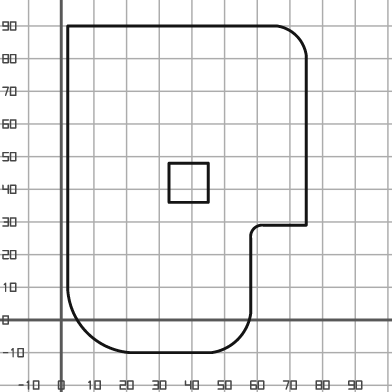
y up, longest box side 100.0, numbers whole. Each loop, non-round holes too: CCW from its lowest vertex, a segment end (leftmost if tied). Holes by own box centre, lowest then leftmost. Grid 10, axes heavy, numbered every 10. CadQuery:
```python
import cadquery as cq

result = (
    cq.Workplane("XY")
    .moveTo(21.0, -10.0)
    .lineTo(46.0, -10.0)
    .threePointArc((54.0, -6.0), (58.0, 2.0))
    .lineTo(58.0, 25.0)
    .threePointArc((59.0, 28.0), (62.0, 29.0))
    .lineTo(75.0, 29.0)
    .lineTo(75.0, 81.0)
    .threePointArc((72.0, 87.0), (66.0, 90.0))
    .lineTo(2.0, 90.0)
    .lineTo(2.0, 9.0)
    .threePointArc((8.0, -4.0), (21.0, -10.0))
    .close()
    .moveTo(33.0, 36.0)
    .lineTo(45.0, 36.0)
    .lineTo(45.0, 48.0)
    .lineTo(33.0, 48.0)
    .close()
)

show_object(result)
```